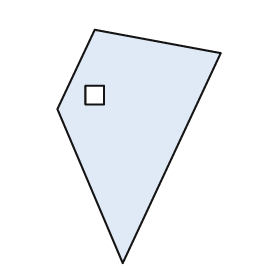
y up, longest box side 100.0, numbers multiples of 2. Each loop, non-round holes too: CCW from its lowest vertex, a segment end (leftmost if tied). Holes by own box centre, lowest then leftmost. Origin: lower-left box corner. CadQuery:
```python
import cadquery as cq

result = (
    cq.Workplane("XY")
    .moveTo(28.0, 0.0)
    .lineTo(70.0, 90.0)
    .lineTo(16.0, 100.0)
    .lineTo(0.0, 66.0)
    .close()
    .moveTo(12.0, 68.0)
    .lineTo(20.0, 68.0)
    .lineTo(20.0, 76.0)
    .lineTo(12.0, 76.0)
    .close()
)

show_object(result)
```